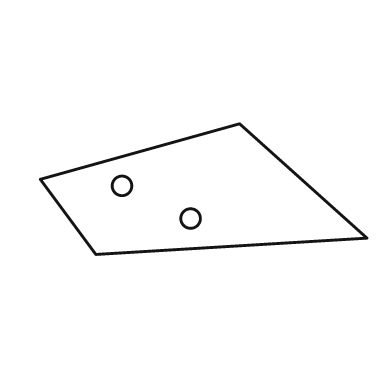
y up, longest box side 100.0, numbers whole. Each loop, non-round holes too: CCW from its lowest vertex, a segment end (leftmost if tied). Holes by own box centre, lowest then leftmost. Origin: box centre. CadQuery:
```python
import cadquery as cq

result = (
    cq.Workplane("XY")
    .moveTo(-33.0, -20.0)
    .lineTo(50.0, -15.0)
    .lineTo(11.0, 20.0)
    .lineTo(-50.0, 3.0)
    .close()
    .moveTo(-4.0, -9.0)
    .circle(3.0)
    .moveTo(-25.0, 1.0)
    .circle(3.0)
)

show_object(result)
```